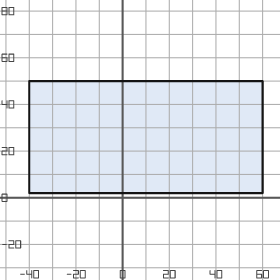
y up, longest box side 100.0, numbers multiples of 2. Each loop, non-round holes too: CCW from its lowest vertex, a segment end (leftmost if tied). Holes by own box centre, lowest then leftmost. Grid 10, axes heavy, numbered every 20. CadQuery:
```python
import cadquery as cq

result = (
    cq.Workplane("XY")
    .moveTo(-40.0, 2.0)
    .lineTo(60.0, 2.0)
    .lineTo(60.0, 50.0)
    .lineTo(-40.0, 50.0)
    .close()
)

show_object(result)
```